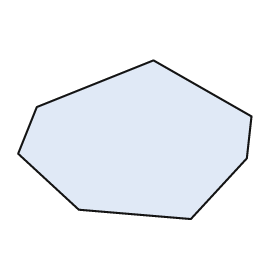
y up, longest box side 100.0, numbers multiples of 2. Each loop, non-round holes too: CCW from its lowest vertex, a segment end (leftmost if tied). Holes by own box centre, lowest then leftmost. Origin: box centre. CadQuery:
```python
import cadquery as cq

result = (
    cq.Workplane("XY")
    .moveTo(24.0, -34.0)
    .lineTo(48.0, -8.0)
    .lineTo(50.0, 10.0)
    .lineTo(8.0, 34.0)
    .lineTo(-42.0, 14.0)
    .lineTo(-50.0, -6.0)
    .lineTo(-24.0, -30.0)
    .close()
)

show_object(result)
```